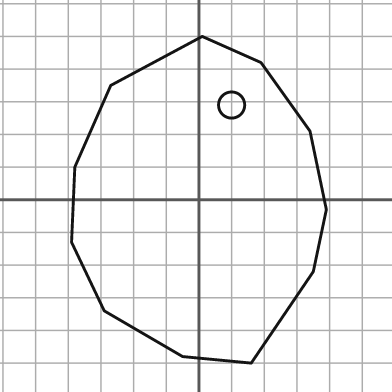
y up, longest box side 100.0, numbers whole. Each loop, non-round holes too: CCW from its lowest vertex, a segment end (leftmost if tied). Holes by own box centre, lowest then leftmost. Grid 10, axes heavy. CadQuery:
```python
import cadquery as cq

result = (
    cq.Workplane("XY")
    .moveTo(16.0, -50.0)
    .lineTo(35.0, -22.0)
    .lineTo(39.0, -3.0)
    .lineTo(34.0, 21.0)
    .lineTo(19.0, 42.0)
    .lineTo(1.0, 50.0)
    .lineTo(-27.0, 35.0)
    .lineTo(-38.0, 10.0)
    .lineTo(-39.0, -13.0)
    .lineTo(-29.0, -34.0)
    .lineTo(-5.0, -48.0)
    .close()
    .moveTo(10.0, 29.0)
    .circle(4.0)
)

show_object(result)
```